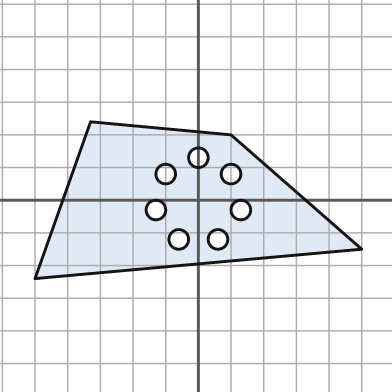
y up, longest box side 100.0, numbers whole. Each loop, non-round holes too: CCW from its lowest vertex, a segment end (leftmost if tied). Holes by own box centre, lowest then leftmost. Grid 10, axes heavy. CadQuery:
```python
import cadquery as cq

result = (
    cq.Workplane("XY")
    .moveTo(-50.0, -24.0)
    .lineTo(50.0, -15.0)
    .lineTo(10.0, 20.0)
    .lineTo(-33.0, 24.0)
    .close()
    .moveTo(-6.0, -12.0)
    .circle(3.0)
    .moveTo(6.0, -12.0)
    .circle(3.0)
    .moveTo(-13.0, -3.0)
    .circle(3.0)
    .moveTo(13.0, -3.0)
    .circle(3.0)
    .moveTo(-10.0, 8.0)
    .circle(3.0)
    .moveTo(10.0, 8.0)
    .circle(3.0)
    .moveTo(0.0, 13.0)
    .circle(3.0)
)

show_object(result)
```